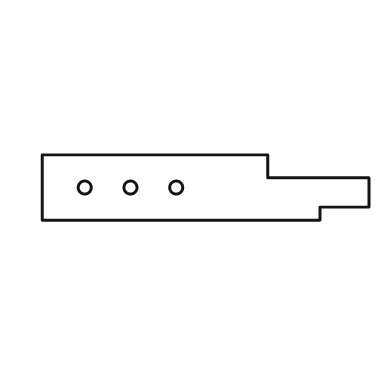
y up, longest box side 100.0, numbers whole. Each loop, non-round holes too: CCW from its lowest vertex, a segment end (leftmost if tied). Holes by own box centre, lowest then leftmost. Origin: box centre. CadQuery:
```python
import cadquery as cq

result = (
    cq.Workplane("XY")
    .moveTo(-50.0, -10.0)
    .lineTo(35.0, -10.0)
    .lineTo(35.0, -6.0)
    .lineTo(50.0, -6.0)
    .lineTo(50.0, 3.0)
    .lineTo(19.0, 3.0)
    .lineTo(19.0, 10.0)
    .lineTo(-50.0, 10.0)
    .close()
    .moveTo(-37.0, 0.0)
    .circle(2.0)
    .moveTo(-23.0, 0.0)
    .circle(2.0)
    .moveTo(-9.0, 0.0)
    .circle(2.0)
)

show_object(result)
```